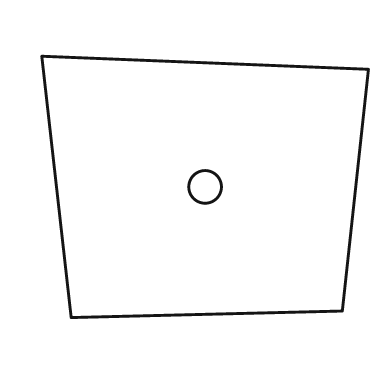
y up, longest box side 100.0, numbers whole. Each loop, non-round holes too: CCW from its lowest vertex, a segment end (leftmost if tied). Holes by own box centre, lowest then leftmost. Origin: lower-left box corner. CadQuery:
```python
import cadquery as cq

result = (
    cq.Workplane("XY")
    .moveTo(9.0, 0.0)
    .lineTo(92.0, 2.0)
    .lineTo(100.0, 76.0)
    .lineTo(0.0, 80.0)
    .close()
    .moveTo(50.0, 40.0)
    .circle(5.0)
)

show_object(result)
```